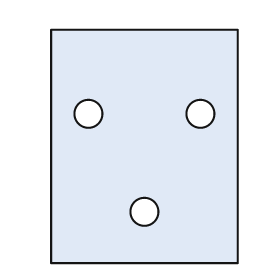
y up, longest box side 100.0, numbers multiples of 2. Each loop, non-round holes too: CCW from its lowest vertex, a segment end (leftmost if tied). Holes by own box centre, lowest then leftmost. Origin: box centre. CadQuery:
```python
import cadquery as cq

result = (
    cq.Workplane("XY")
    .moveTo(-40.0, -50.0)
    .lineTo(40.0, -50.0)
    .lineTo(40.0, 50.0)
    .lineTo(-40.0, 50.0)
    .close()
    .moveTo(0.0, -28.0)
    .circle(6.0)
    .moveTo(-24.0, 14.0)
    .circle(6.0)
    .moveTo(24.0, 14.0)
    .circle(6.0)
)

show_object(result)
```